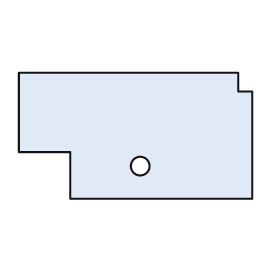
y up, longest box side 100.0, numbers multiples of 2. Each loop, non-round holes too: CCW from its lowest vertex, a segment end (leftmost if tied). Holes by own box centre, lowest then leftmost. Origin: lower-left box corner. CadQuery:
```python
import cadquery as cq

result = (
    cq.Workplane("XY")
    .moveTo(22.0, 0.0)
    .lineTo(100.0, 0.0)
    .lineTo(100.0, 46.0)
    .lineTo(94.0, 46.0)
    .lineTo(94.0, 54.0)
    .lineTo(0.0, 54.0)
    .lineTo(0.0, 20.0)
    .lineTo(22.0, 20.0)
    .close()
    .moveTo(52.0, 14.0)
    .circle(4.0)
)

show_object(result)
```